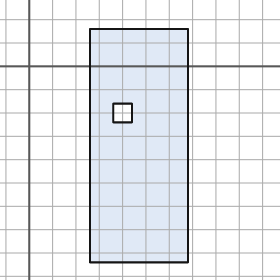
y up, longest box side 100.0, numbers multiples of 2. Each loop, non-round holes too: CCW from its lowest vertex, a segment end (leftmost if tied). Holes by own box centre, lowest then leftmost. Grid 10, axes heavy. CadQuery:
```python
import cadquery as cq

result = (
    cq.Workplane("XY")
    .moveTo(26.0, -84.0)
    .lineTo(68.0, -84.0)
    .lineTo(68.0, 16.0)
    .lineTo(26.0, 16.0)
    .close()
    .moveTo(36.0, -24.0)
    .lineTo(44.0, -24.0)
    .lineTo(44.0, -16.0)
    .lineTo(36.0, -16.0)
    .close()
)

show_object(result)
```